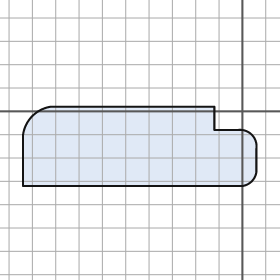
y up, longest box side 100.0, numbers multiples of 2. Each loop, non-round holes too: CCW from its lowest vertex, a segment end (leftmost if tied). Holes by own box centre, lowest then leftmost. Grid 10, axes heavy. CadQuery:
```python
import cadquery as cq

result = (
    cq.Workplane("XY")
    .moveTo(-94.0, -32.0)
    .lineTo(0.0, -32.0)
    .threePointArc((4.0, -30.0), (6.0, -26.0))
    .lineTo(6.0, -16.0)
    .threePointArc((4.0, -10.0), (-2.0, -8.0))
    .lineTo(-12.0, -8.0)
    .lineTo(-12.0, 2.0)
    .lineTo(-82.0, 2.0)
    .threePointArc((-90.0, -2.0), (-94.0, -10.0))
    .close()
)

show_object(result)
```